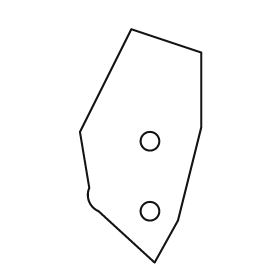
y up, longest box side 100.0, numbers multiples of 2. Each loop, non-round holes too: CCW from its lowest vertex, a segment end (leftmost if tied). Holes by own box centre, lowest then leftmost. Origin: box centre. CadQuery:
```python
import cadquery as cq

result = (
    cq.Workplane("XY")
    .moveTo(6.0, -50.0)
    .lineTo(16.0, -32.0)
    .lineTo(26.0, 8.0)
    .lineTo(26.0, 40.0)
    .lineTo(-4.0, 50.0)
    .lineTo(-26.0, 6.0)
    .lineTo(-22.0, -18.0)
    .threePointArc((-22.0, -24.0), (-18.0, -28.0))
    .close()
    .moveTo(4.0, -28.0)
    .circle(4.0)
    .moveTo(4.0, 2.0)
    .circle(4.0)
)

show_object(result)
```